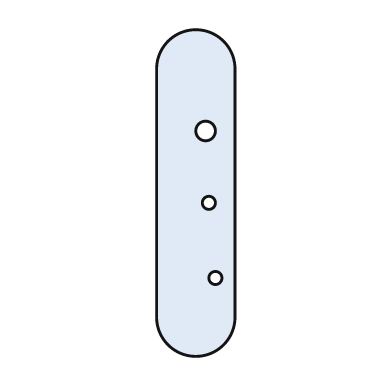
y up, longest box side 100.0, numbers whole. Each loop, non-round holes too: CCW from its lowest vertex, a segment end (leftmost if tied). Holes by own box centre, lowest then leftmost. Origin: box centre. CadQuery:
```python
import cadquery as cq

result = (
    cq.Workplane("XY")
    .moveTo(-12.0, -38.0)
    .threePointArc((0.0, -50.0), (12.0, -38.0))
    .lineTo(12.0, 38.0)
    .threePointArc((0.0, 50.0), (-12.0, 38.0))
    .close()
    .moveTo(6.0, -26.0)
    .circle(2.0)
    .moveTo(4.0, -3.0)
    .circle(2.0)
    .moveTo(3.0, 19.0)
    .circle(3.0)
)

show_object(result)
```